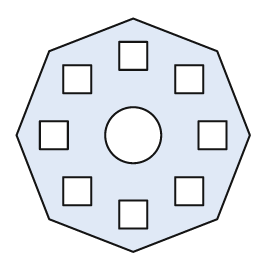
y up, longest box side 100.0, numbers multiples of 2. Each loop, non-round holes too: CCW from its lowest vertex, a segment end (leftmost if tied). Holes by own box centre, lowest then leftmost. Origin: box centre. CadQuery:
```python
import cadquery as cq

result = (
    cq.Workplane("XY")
    .moveTo(0.0, -50.0)
    .lineTo(36.0, -36.0)
    .lineTo(50.0, 0.0)
    .lineTo(36.0, 36.0)
    .lineTo(0.0, 50.0)
    .lineTo(-36.0, 36.0)
    .lineTo(-50.0, 0.0)
    .lineTo(-36.0, -36.0)
    .close()
    .moveTo(-6.0, -40.0)
    .lineTo(6.0, -40.0)
    .lineTo(6.0, -28.0)
    .lineTo(-6.0, -28.0)
    .close()
    .moveTo(-30.0, -30.0)
    .lineTo(-18.0, -30.0)
    .lineTo(-18.0, -18.0)
    .lineTo(-30.0, -18.0)
    .close()
    .moveTo(18.0, -30.0)
    .lineTo(30.0, -30.0)
    .lineTo(30.0, -18.0)
    .lineTo(18.0, -18.0)
    .close()
    .moveTo(-40.0, -6.0)
    .lineTo(-28.0, -6.0)
    .lineTo(-28.0, 6.0)
    .lineTo(-40.0, 6.0)
    .close()
    .moveTo(0.0, 0.0)
    .circle(12.0)
    .moveTo(28.0, -6.0)
    .lineTo(40.0, -6.0)
    .lineTo(40.0, 6.0)
    .lineTo(28.0, 6.0)
    .close()
    .moveTo(-30.0, 18.0)
    .lineTo(-18.0, 18.0)
    .lineTo(-18.0, 30.0)
    .lineTo(-30.0, 30.0)
    .close()
    .moveTo(18.0, 18.0)
    .lineTo(30.0, 18.0)
    .lineTo(30.0, 30.0)
    .lineTo(18.0, 30.0)
    .close()
    .moveTo(-6.0, 28.0)
    .lineTo(6.0, 28.0)
    .lineTo(6.0, 40.0)
    .lineTo(-6.0, 40.0)
    .close()
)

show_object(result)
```